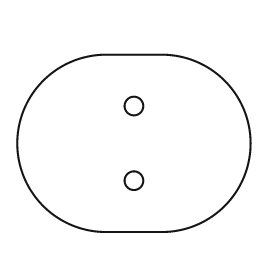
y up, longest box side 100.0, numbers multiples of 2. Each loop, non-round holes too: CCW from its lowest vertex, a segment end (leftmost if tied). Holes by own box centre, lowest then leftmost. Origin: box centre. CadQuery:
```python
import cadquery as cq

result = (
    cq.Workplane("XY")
    .moveTo(-12.0, -38.0)
    .lineTo(12.0, -38.0)
    .threePointArc((50.0, 0.0), (12.0, 38.0))
    .lineTo(-12.0, 38.0)
    .threePointArc((-50.0, 0.0), (-12.0, -38.0))
    .close()
    .moveTo(0.0, -16.0)
    .circle(4.0)
    .moveTo(0.0, 16.0)
    .circle(4.0)
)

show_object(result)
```